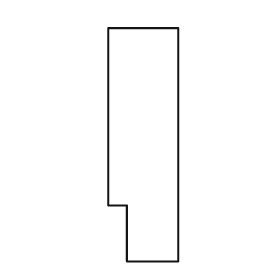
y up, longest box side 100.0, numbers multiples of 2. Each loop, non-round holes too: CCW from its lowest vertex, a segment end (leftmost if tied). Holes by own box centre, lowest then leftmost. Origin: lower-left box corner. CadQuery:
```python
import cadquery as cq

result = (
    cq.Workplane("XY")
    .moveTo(8.0, 0.0)
    .lineTo(30.0, 0.0)
    .lineTo(30.0, 100.0)
    .lineTo(0.0, 100.0)
    .lineTo(0.0, 24.0)
    .lineTo(8.0, 24.0)
    .close()
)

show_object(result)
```